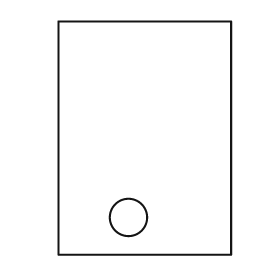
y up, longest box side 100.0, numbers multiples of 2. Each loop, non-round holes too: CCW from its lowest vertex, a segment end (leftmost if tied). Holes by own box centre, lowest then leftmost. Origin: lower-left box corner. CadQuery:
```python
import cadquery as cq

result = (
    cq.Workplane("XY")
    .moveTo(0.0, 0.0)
    .lineTo(74.0, 0.0)
    .lineTo(74.0, 100.0)
    .lineTo(0.0, 100.0)
    .close()
    .moveTo(30.0, 16.0)
    .circle(8.0)
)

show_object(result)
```